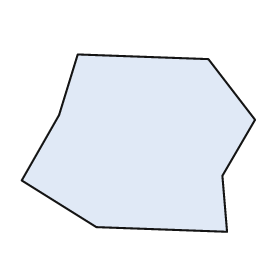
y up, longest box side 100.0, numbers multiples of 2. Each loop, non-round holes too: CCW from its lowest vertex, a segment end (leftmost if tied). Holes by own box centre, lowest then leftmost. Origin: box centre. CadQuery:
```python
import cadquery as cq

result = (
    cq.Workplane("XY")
    .moveTo(38.0, -38.0)
    .lineTo(36.0, -14.0)
    .lineTo(50.0, 10.0)
    .lineTo(30.0, 36.0)
    .lineTo(-26.0, 38.0)
    .lineTo(-34.0, 12.0)
    .lineTo(-50.0, -16.0)
    .lineTo(-18.0, -36.0)
    .close()
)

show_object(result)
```